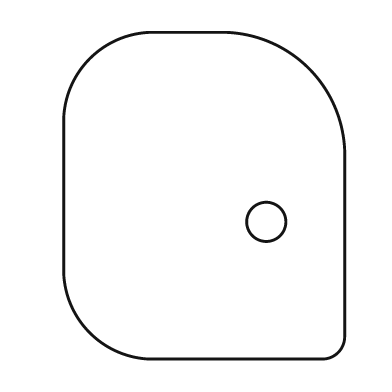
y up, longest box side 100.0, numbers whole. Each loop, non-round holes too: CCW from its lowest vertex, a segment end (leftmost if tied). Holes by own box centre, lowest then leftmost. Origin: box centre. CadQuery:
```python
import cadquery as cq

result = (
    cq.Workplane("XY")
    .moveTo(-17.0, -50.0)
    .lineTo(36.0, -50.0)
    .threePointArc((41.0, -48.0), (43.0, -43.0))
    .lineTo(43.0, 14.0)
    .threePointArc((32.0, 39.0), (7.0, 50.0))
    .lineTo(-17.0, 50.0)
    .threePointArc((-35.0, 42.0), (-43.0, 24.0))
    .lineTo(-43.0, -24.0)
    .threePointArc((-35.0, -42.0), (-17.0, -50.0))
    .close()
    .moveTo(19.0, -8.0)
    .circle(6.0)
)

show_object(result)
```